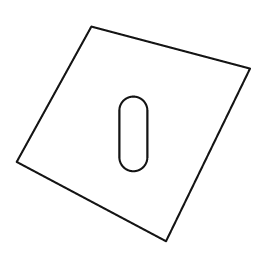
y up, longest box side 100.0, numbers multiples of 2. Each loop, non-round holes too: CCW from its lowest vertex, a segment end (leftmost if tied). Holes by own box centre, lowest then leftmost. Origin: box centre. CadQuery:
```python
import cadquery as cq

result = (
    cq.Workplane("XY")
    .moveTo(14.0, -46.0)
    .lineTo(50.0, 28.0)
    .lineTo(-18.0, 46.0)
    .lineTo(-50.0, -12.0)
    .close()
    .moveTo(-6.0, -10.0)
    .threePointArc((0.0, -16.0), (6.0, -10.0))
    .lineTo(6.0, 10.0)
    .threePointArc((0.0, 16.0), (-6.0, 10.0))
    .close()
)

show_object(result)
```